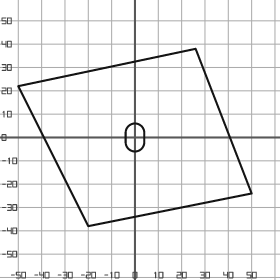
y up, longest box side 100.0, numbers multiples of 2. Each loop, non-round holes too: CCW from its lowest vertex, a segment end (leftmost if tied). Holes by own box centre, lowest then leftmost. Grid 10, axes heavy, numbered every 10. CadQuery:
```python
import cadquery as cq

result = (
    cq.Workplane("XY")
    .moveTo(-20.0, -38.0)
    .lineTo(50.0, -24.0)
    .lineTo(26.0, 38.0)
    .lineTo(-50.0, 22.0)
    .close()
    .moveTo(-4.0, -2.0)
    .threePointArc((0.0, -6.0), (4.0, -2.0))
    .lineTo(4.0, 2.0)
    .threePointArc((0.0, 6.0), (-4.0, 2.0))
    .close()
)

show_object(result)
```